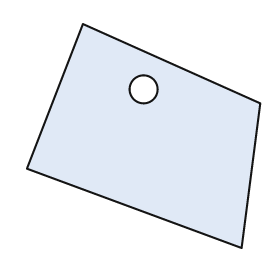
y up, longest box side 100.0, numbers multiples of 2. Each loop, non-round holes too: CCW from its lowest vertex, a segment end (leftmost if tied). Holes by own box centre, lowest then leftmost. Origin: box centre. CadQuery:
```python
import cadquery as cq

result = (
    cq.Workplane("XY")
    .moveTo(42.0, -48.0)
    .lineTo(50.0, 14.0)
    .lineTo(-26.0, 48.0)
    .lineTo(-50.0, -14.0)
    .close()
    .moveTo(0.0, 20.0)
    .circle(6.0)
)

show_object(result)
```